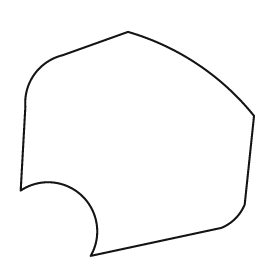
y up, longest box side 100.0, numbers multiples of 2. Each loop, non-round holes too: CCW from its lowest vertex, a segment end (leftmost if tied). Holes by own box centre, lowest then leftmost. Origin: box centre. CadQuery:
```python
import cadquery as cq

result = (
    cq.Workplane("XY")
    .moveTo(-20.0, -48.0)
    .lineTo(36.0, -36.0)
    .threePointArc((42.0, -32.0), (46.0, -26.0))
    .lineTo(50.0, 12.0)
    .threePointArc((26.0, 34.0), (-4.0, 48.0))
    .lineTo(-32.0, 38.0)
    .threePointArc((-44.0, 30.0), (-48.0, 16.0))
    .lineTo(-50.0, -20.0)
    .threePointArc((-24.0, -22.0), (-20.0, -48.0))
    .close()
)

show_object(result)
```